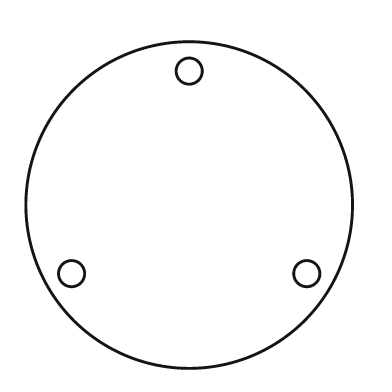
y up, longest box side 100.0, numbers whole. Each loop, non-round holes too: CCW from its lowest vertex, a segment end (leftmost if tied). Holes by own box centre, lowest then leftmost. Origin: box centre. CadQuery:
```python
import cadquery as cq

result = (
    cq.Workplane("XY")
    .moveTo(0.0, 0.0)
    .circle(50.0)
    .moveTo(-36.0, -21.0)
    .circle(4.0)
    .moveTo(36.0, -21.0)
    .circle(4.0)
    .moveTo(0.0, 41.0)
    .circle(4.0)
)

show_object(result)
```